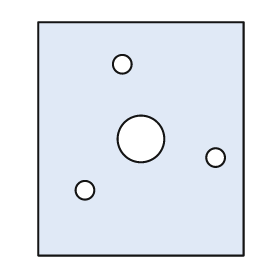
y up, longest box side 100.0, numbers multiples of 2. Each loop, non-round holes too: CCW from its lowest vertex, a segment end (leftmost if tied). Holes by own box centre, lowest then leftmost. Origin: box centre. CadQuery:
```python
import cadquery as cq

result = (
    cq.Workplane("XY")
    .moveTo(-44.0, -50.0)
    .lineTo(44.0, -50.0)
    .lineTo(44.0, 50.0)
    .lineTo(-44.0, 50.0)
    .close()
    .moveTo(-24.0, -22.0)
    .circle(4.0)
    .moveTo(32.0, -8.0)
    .circle(4.0)
    .moveTo(0.0, 0.0)
    .circle(10.0)
    .moveTo(-8.0, 32.0)
    .circle(4.0)
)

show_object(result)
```